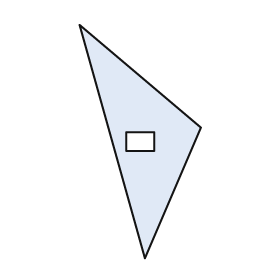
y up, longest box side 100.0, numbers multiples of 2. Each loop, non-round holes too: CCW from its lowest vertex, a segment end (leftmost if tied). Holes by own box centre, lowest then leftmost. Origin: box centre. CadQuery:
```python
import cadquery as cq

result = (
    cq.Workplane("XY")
    .moveTo(2.0, -50.0)
    .lineTo(26.0, 6.0)
    .lineTo(-26.0, 50.0)
    .close()
    .moveTo(-6.0, -4.0)
    .lineTo(6.0, -4.0)
    .lineTo(6.0, 4.0)
    .lineTo(-6.0, 4.0)
    .close()
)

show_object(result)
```